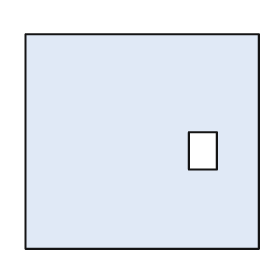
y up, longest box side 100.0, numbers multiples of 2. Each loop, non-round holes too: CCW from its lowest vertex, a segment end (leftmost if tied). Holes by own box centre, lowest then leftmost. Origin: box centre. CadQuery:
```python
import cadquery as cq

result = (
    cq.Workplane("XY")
    .moveTo(-50.0, -46.0)
    .lineTo(50.0, -46.0)
    .lineTo(50.0, 46.0)
    .lineTo(-50.0, 46.0)
    .close()
    .moveTo(20.0, -12.0)
    .lineTo(32.0, -12.0)
    .lineTo(32.0, 4.0)
    .lineTo(20.0, 4.0)
    .close()
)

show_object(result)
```